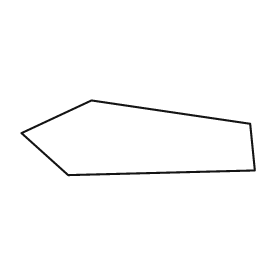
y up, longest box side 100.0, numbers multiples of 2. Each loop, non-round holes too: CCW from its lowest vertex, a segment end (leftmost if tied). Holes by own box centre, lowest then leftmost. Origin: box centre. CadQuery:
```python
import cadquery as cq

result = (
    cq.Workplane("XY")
    .moveTo(-30.0, -16.0)
    .lineTo(50.0, -14.0)
    .lineTo(48.0, 6.0)
    .lineTo(-20.0, 16.0)
    .lineTo(-50.0, 2.0)
    .close()
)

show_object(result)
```